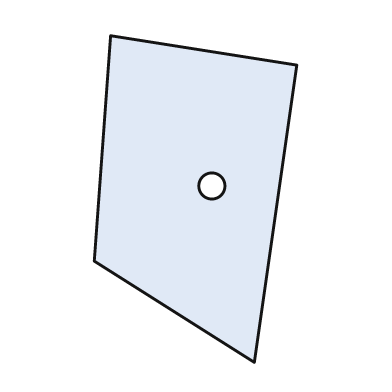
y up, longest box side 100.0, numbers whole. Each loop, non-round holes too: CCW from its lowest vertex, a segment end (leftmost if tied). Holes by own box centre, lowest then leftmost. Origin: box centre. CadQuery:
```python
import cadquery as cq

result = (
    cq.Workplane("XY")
    .moveTo(18.0, -50.0)
    .lineTo(31.0, 41.0)
    .lineTo(-26.0, 50.0)
    .lineTo(-31.0, -19.0)
    .close()
    .moveTo(5.0, 4.0)
    .circle(4.0)
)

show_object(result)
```